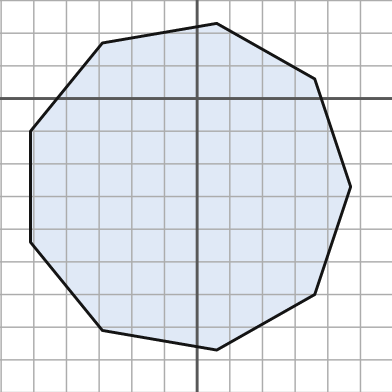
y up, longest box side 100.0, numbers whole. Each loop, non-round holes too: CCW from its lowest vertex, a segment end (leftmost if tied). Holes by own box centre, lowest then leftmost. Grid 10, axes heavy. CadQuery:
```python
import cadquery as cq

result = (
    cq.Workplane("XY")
    .moveTo(6.0, -77.0)
    .lineTo(36.0, -60.0)
    .lineTo(47.0, -27.0)
    .lineTo(36.0, 6.0)
    .lineTo(6.0, 23.0)
    .lineTo(-29.0, 17.0)
    .lineTo(-51.0, -10.0)
    .lineTo(-51.0, -44.0)
    .lineTo(-29.0, -71.0)
    .close()
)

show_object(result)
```